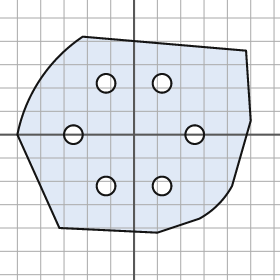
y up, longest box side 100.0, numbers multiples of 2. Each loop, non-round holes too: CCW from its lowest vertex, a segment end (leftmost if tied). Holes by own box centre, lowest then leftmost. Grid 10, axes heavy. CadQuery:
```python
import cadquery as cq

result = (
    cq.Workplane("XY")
    .moveTo(10.0, -42.0)
    .lineTo(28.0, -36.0)
    .threePointArc((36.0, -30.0), (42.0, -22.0))
    .lineTo(50.0, 6.0)
    .lineTo(48.0, 36.0)
    .lineTo(-22.0, 42.0)
    .threePointArc((-40.0, 24.0), (-50.0, 0.0))
    .lineTo(-32.0, -40.0)
    .close()
    .moveTo(-12.0, -22.0)
    .circle(4.0)
    .moveTo(12.0, -22.0)
    .circle(4.0)
    .moveTo(-26.0, 0.0)
    .circle(4.0)
    .moveTo(26.0, 0.0)
    .circle(4.0)
    .moveTo(-12.0, 22.0)
    .circle(4.0)
    .moveTo(12.0, 22.0)
    .circle(4.0)
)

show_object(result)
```